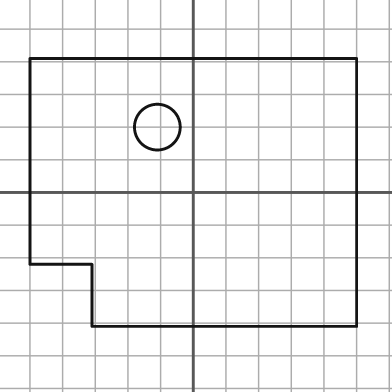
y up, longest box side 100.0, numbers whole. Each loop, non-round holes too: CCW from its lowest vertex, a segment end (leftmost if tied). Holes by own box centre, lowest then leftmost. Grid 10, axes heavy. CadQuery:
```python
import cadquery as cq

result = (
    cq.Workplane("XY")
    .moveTo(-31.0, -41.0)
    .lineTo(50.0, -41.0)
    .lineTo(50.0, 41.0)
    .lineTo(-50.0, 41.0)
    .lineTo(-50.0, -22.0)
    .lineTo(-31.0, -22.0)
    .close()
    .moveTo(-11.0, 20.0)
    .circle(7.0)
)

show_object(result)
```